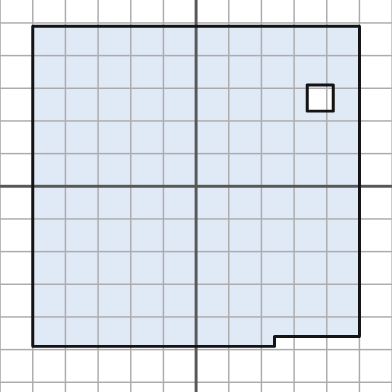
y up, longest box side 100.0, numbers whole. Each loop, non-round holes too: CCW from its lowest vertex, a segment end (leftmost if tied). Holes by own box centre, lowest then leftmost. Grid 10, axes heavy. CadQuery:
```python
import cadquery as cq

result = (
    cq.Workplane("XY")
    .moveTo(-50.0, -49.0)
    .lineTo(24.0, -49.0)
    .lineTo(24.0, -46.0)
    .lineTo(50.0, -46.0)
    .lineTo(50.0, 49.0)
    .lineTo(-50.0, 49.0)
    .close()
    .moveTo(34.0, 23.0)
    .lineTo(42.0, 23.0)
    .lineTo(42.0, 31.0)
    .lineTo(34.0, 31.0)
    .close()
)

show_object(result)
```